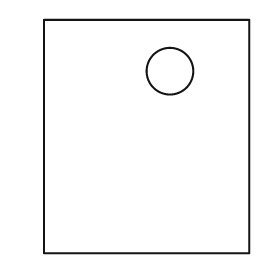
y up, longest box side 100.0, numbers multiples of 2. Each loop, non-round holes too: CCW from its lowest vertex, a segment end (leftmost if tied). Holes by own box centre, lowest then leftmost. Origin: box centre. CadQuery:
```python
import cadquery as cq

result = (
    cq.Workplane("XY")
    .moveTo(-44.0, -50.0)
    .lineTo(44.0, -50.0)
    .lineTo(44.0, 50.0)
    .lineTo(-44.0, 50.0)
    .close()
    .moveTo(10.0, 28.0)
    .circle(10.0)
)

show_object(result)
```